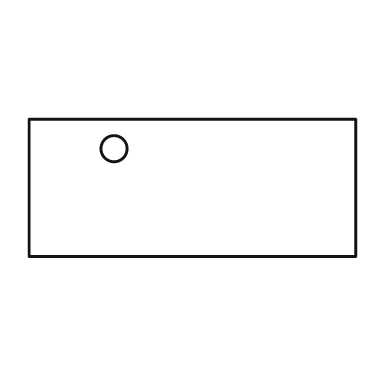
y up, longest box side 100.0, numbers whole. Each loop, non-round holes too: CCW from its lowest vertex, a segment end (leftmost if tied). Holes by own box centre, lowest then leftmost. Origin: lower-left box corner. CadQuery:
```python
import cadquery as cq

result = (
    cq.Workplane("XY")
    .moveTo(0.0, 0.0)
    .lineTo(100.0, 0.0)
    .lineTo(100.0, 42.0)
    .lineTo(0.0, 42.0)
    .close()
    .moveTo(26.0, 33.0)
    .circle(4.0)
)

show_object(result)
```